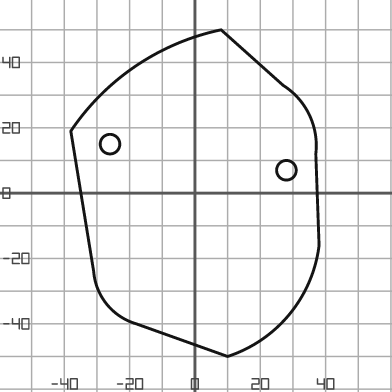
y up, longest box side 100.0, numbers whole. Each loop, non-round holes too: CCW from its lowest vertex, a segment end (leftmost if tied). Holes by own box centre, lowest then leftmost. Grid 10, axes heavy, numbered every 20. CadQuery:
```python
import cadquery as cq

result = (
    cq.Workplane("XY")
    .moveTo(10.0, -50.0)
    .threePointArc((29.0, -37.0), (38.0, -16.0))
    .lineTo(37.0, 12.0)
    .threePointArc((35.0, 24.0), (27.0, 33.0))
    .lineTo(8.0, 50.0)
    .threePointArc((-18.0, 39.0), (-38.0, 19.0))
    .lineTo(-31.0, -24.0)
    .threePointArc((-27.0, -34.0), (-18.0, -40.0))
    .close()
    .moveTo(28.0, 7.0)
    .circle(3.0)
    .moveTo(-26.0, 15.0)
    .circle(3.0)
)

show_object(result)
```